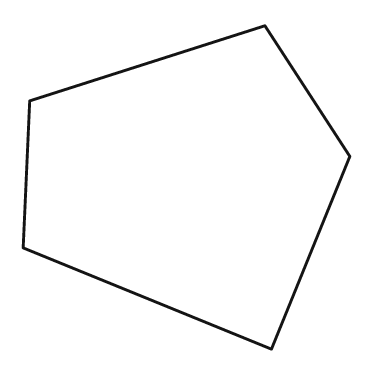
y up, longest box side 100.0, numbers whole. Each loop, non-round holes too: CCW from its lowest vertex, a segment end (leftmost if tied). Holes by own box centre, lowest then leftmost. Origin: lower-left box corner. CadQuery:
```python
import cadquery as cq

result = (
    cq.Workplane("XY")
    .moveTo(76.0, 0.0)
    .lineTo(100.0, 59.0)
    .lineTo(74.0, 99.0)
    .lineTo(2.0, 76.0)
    .lineTo(0.0, 31.0)
    .close()
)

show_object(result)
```